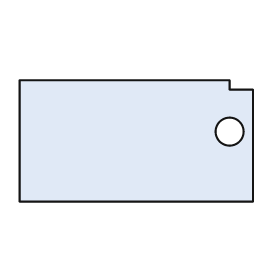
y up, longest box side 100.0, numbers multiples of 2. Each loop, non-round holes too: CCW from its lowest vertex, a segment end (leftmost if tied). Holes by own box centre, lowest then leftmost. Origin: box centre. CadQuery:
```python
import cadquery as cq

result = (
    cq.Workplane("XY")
    .moveTo(-50.0, -26.0)
    .lineTo(50.0, -26.0)
    .lineTo(50.0, 22.0)
    .lineTo(40.0, 22.0)
    .lineTo(40.0, 26.0)
    .lineTo(-50.0, 26.0)
    .close()
    .moveTo(40.0, 4.0)
    .circle(6.0)
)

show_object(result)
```